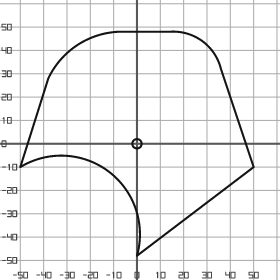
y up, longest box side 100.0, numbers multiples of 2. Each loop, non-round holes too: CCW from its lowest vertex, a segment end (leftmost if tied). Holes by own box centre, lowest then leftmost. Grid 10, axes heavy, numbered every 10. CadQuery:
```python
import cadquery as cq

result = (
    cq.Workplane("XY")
    .moveTo(0.0, -48.0)
    .lineTo(50.0, -10.0)
    .lineTo(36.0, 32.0)
    .threePointArc((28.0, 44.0), (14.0, 48.0))
    .lineTo(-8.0, 48.0)
    .threePointArc((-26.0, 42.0), (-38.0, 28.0))
    .lineTo(-50.0, -10.0)
    .threePointArc((-12.0, -12.0), (0.0, -48.0))
    .close()
    .moveTo(0.0, 0.0)
    .circle(2.0)
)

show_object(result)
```